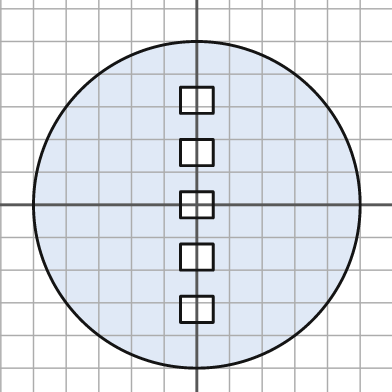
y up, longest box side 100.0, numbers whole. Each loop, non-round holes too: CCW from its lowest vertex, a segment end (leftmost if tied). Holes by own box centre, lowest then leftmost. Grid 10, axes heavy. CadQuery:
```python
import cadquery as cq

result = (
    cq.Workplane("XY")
    .moveTo(0.0, 0.0)
    .circle(50.0)
    .moveTo(-5.0, -36.0)
    .lineTo(5.0, -36.0)
    .lineTo(5.0, -28.0)
    .lineTo(-5.0, -28.0)
    .close()
    .moveTo(-5.0, -20.0)
    .lineTo(5.0, -20.0)
    .lineTo(5.0, -12.0)
    .lineTo(-5.0, -12.0)
    .close()
    .moveTo(-5.0, -4.0)
    .lineTo(5.0, -4.0)
    .lineTo(5.0, 4.0)
    .lineTo(-5.0, 4.0)
    .close()
    .moveTo(-5.0, 12.0)
    .lineTo(5.0, 12.0)
    .lineTo(5.0, 20.0)
    .lineTo(-5.0, 20.0)
    .close()
    .moveTo(-5.0, 28.0)
    .lineTo(5.0, 28.0)
    .lineTo(5.0, 36.0)
    .lineTo(-5.0, 36.0)
    .close()
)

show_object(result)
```